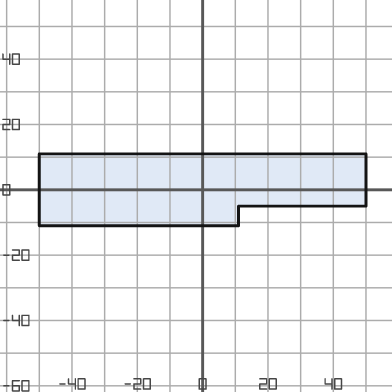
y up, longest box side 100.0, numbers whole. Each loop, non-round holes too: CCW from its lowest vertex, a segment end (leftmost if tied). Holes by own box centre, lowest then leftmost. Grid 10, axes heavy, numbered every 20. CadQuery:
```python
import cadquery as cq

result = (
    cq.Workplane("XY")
    .moveTo(-50.0, -11.0)
    .lineTo(11.0, -11.0)
    .lineTo(11.0, -5.0)
    .lineTo(50.0, -5.0)
    .lineTo(50.0, 11.0)
    .lineTo(-50.0, 11.0)
    .close()
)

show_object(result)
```